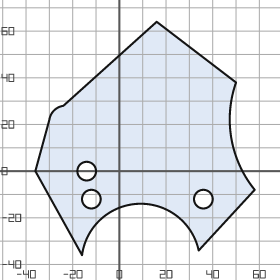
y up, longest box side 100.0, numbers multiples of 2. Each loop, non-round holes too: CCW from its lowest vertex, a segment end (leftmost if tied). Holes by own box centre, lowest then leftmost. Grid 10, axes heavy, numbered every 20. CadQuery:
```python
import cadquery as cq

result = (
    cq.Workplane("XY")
    .moveTo(-16.0, -36.0)
    .threePointArc((8.0, -14.0), (34.0, -34.0))
    .lineTo(58.0, -8.0)
    .threePointArc((48.0, 14.0), (50.0, 38.0))
    .lineTo(16.0, 64.0)
    .lineTo(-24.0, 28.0)
    .threePointArc((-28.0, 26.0), (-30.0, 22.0))
    .lineTo(-36.0, 0.0)
    .close()
    .moveTo(-12.0, -12.0)
    .circle(4.0)
    .moveTo(36.0, -12.0)
    .circle(4.0)
    .moveTo(-14.0, 0.0)
    .circle(4.0)
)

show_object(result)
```